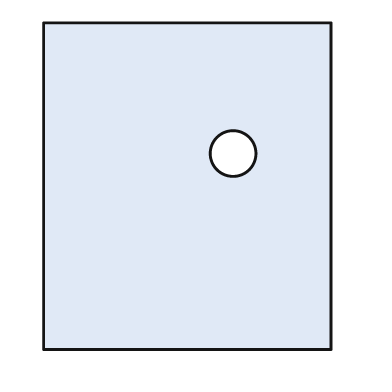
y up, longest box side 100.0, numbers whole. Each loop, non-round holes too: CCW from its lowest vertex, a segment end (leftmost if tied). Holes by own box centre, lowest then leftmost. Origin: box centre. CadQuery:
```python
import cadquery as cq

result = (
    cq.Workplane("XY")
    .moveTo(-44.0, -50.0)
    .lineTo(44.0, -50.0)
    .lineTo(44.0, 50.0)
    .lineTo(-44.0, 50.0)
    .close()
    .moveTo(14.0, 10.0)
    .circle(7.0)
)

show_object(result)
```